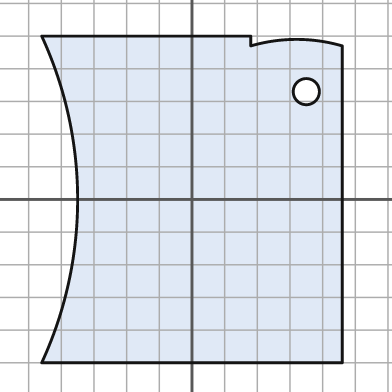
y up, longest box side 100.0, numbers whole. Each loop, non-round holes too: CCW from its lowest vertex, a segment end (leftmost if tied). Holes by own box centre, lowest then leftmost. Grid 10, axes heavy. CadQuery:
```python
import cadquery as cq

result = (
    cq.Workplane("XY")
    .moveTo(-46.0, -50.0)
    .lineTo(46.0, -50.0)
    .lineTo(46.0, 47.0)
    .threePointArc((32.0, 49.0), (18.0, 47.0))
    .lineTo(18.0, 50.0)
    .lineTo(-46.0, 50.0)
    .threePointArc((-35.0, 0.0), (-46.0, -50.0))
    .close()
    .moveTo(35.0, 33.0)
    .circle(4.0)
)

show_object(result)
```